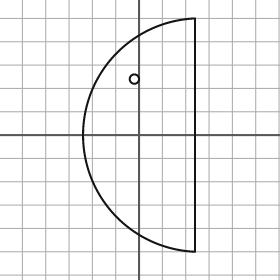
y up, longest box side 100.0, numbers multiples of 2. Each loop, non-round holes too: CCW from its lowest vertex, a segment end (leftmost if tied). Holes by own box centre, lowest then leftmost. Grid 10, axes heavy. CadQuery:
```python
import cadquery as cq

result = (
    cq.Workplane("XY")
    .moveTo(24.0, -50.0)
    .lineTo(24.0, 50.0)
    .threePointArc((-24.0, 0.0), (24.0, -50.0))
    .close()
    .moveTo(-2.0, 24.0)
    .circle(2.0)
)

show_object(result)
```